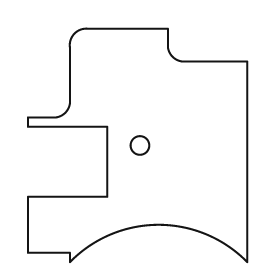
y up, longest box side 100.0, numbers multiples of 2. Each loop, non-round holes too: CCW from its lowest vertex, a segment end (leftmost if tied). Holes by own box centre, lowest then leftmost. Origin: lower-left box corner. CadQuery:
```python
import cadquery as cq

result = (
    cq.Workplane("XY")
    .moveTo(18.0, 0.0)
    .threePointArc((56.0, 16.0), (94.0, 0.0))
    .lineTo(94.0, 86.0)
    .lineTo(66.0, 86.0)
    .threePointArc((62.0, 88.0), (60.0, 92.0))
    .lineTo(60.0, 100.0)
    .lineTo(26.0, 100.0)
    .threePointArc((20.0, 98.0), (18.0, 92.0))
    .lineTo(18.0, 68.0)
    .threePointArc((16.0, 64.0), (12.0, 62.0))
    .lineTo(0.0, 62.0)
    .lineTo(0.0, 58.0)
    .lineTo(34.0, 58.0)
    .lineTo(34.0, 28.0)
    .lineTo(0.0, 28.0)
    .lineTo(0.0, 4.0)
    .lineTo(18.0, 4.0)
    .close()
    .moveTo(48.0, 50.0)
    .circle(4.0)
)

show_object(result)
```